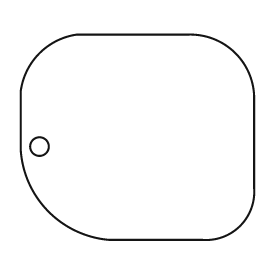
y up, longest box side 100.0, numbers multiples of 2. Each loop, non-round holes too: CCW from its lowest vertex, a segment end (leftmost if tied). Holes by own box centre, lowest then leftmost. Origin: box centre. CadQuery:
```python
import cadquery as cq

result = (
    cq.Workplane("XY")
    .moveTo(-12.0, -44.0)
    .lineTo(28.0, -44.0)
    .threePointArc((44.0, -38.0), (50.0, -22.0))
    .lineTo(50.0, 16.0)
    .threePointArc((42.0, 36.0), (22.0, 44.0))
    .lineTo(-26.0, 44.0)
    .threePointArc((-42.0, 36.0), (-50.0, 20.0))
    .lineTo(-50.0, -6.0)
    .threePointArc((-38.0, -32.0), (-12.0, -44.0))
    .close()
    .moveTo(-42.0, -4.0)
    .circle(4.0)
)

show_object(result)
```